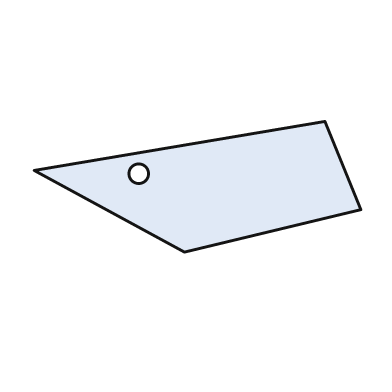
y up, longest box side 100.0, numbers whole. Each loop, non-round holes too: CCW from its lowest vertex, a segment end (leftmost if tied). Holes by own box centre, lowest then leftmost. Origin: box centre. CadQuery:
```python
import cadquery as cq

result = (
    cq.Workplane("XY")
    .moveTo(-4.0, -20.0)
    .lineTo(50.0, -7.0)
    .lineTo(39.0, 20.0)
    .lineTo(-50.0, 5.0)
    .close()
    .moveTo(-18.0, 4.0)
    .circle(3.0)
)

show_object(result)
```